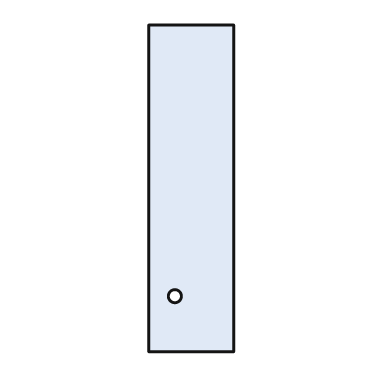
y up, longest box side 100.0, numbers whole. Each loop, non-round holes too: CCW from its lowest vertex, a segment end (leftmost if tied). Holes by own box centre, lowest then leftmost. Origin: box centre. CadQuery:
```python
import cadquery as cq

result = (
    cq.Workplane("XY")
    .moveTo(-13.0, -50.0)
    .lineTo(13.0, -50.0)
    .lineTo(13.0, 50.0)
    .lineTo(-13.0, 50.0)
    .close()
    .moveTo(-5.0, -33.0)
    .circle(2.0)
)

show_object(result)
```